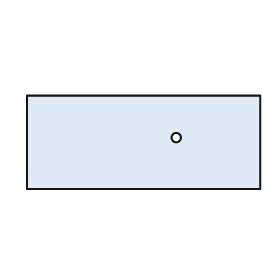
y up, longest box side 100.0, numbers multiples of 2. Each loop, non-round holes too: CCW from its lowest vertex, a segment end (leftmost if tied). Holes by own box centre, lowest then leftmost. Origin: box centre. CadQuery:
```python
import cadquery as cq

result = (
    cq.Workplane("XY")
    .moveTo(-50.0, -20.0)
    .lineTo(50.0, -20.0)
    .lineTo(50.0, 20.0)
    .lineTo(-50.0, 20.0)
    .close()
    .moveTo(14.0, 2.0)
    .circle(2.0)
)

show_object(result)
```